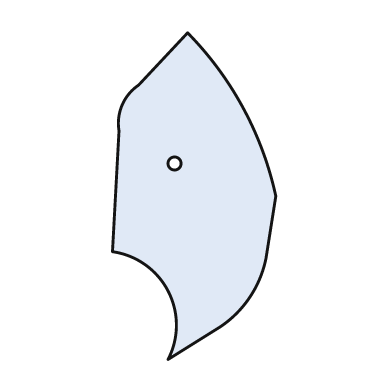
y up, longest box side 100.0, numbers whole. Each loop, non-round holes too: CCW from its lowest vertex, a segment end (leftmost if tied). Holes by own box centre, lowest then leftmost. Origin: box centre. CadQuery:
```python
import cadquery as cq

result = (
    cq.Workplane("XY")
    .moveTo(-8.0, -50.0)
    .lineTo(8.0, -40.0)
    .threePointArc((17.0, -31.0), (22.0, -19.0))
    .lineTo(25.0, 0.0)
    .threePointArc((15.0, 27.0), (-2.0, 50.0))
    .lineTo(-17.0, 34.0)
    .threePointArc((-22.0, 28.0), (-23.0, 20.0))
    .lineTo(-25.0, -17.0)
    .threePointArc((-8.0, -29.0), (-8.0, -50.0))
    .close()
    .moveTo(-6.0, 10.0)
    .circle(2.0)
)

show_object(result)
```